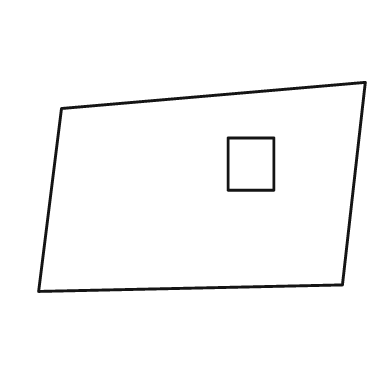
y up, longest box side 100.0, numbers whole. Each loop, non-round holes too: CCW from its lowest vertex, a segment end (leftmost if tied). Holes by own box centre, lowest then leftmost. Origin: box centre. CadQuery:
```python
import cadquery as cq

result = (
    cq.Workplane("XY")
    .moveTo(-50.0, -32.0)
    .lineTo(43.0, -30.0)
    .lineTo(50.0, 32.0)
    .lineTo(-43.0, 24.0)
    .close()
    .moveTo(8.0, -1.0)
    .lineTo(22.0, -1.0)
    .lineTo(22.0, 15.0)
    .lineTo(8.0, 15.0)
    .close()
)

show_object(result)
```